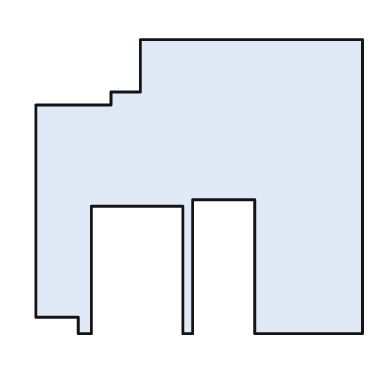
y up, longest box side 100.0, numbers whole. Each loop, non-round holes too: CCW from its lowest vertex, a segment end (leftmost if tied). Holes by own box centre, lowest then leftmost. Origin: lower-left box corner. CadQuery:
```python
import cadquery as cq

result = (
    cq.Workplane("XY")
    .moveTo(13.0, 0.0)
    .lineTo(17.0, 0.0)
    .lineTo(17.0, 39.0)
    .lineTo(45.0, 39.0)
    .lineTo(45.0, 0.0)
    .lineTo(48.0, 0.0)
    .lineTo(48.0, 41.0)
    .lineTo(67.0, 41.0)
    .lineTo(67.0, 0.0)
    .lineTo(100.0, 0.0)
    .lineTo(100.0, 90.0)
    .lineTo(32.0, 90.0)
    .lineTo(32.0, 74.0)
    .lineTo(23.0, 74.0)
    .lineTo(23.0, 70.0)
    .lineTo(0.0, 70.0)
    .lineTo(0.0, 5.0)
    .lineTo(13.0, 5.0)
    .close()
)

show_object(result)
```